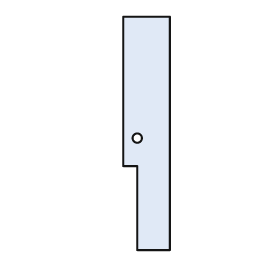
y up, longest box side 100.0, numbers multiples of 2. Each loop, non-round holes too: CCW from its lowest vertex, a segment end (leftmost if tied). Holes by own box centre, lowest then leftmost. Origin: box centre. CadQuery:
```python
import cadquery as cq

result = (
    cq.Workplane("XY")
    .moveTo(-4.0, -50.0)
    .lineTo(10.0, -50.0)
    .lineTo(10.0, 50.0)
    .lineTo(-10.0, 50.0)
    .lineTo(-10.0, -14.0)
    .lineTo(-4.0, -14.0)
    .close()
    .moveTo(-4.0, -2.0)
    .circle(2.0)
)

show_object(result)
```